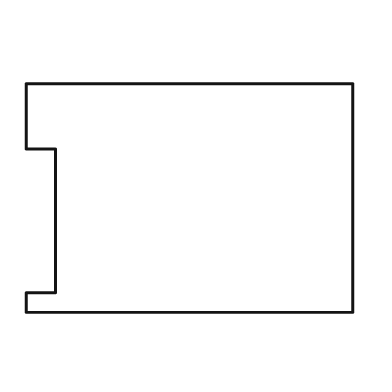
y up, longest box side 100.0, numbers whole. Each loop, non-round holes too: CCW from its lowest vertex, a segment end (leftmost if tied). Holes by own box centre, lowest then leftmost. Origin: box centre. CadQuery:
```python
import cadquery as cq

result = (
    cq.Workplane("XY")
    .moveTo(-50.0, -35.0)
    .lineTo(50.0, -35.0)
    .lineTo(50.0, 35.0)
    .lineTo(-50.0, 35.0)
    .lineTo(-50.0, 15.0)
    .lineTo(-41.0, 15.0)
    .lineTo(-41.0, -29.0)
    .lineTo(-50.0, -29.0)
    .close()
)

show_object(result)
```